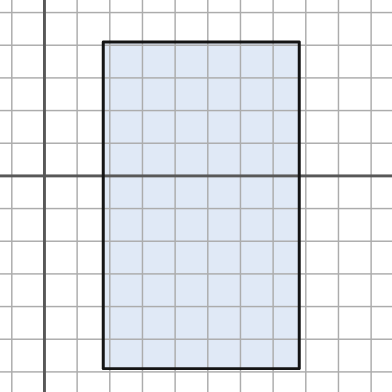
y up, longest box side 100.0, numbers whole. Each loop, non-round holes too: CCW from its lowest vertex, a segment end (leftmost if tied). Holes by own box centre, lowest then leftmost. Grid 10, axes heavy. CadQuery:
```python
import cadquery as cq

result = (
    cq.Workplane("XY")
    .moveTo(18.0, -59.0)
    .lineTo(78.0, -59.0)
    .lineTo(78.0, 41.0)
    .lineTo(18.0, 41.0)
    .close()
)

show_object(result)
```